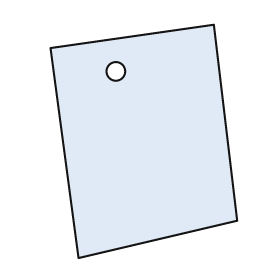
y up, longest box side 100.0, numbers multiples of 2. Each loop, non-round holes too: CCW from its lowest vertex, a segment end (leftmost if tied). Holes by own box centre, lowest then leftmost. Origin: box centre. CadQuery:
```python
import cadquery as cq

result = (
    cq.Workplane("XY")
    .moveTo(-28.0, -50.0)
    .lineTo(40.0, -34.0)
    .lineTo(30.0, 50.0)
    .lineTo(-40.0, 40.0)
    .close()
    .moveTo(-12.0, 30.0)
    .circle(4.0)
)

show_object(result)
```